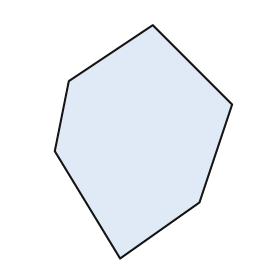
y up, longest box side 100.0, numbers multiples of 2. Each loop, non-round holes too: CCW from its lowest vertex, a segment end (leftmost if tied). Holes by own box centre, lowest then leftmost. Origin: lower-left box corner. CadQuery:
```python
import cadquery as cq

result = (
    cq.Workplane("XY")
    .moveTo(28.0, 0.0)
    .lineTo(62.0, 24.0)
    .lineTo(76.0, 66.0)
    .lineTo(42.0, 100.0)
    .lineTo(6.0, 76.0)
    .lineTo(0.0, 46.0)
    .close()
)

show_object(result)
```